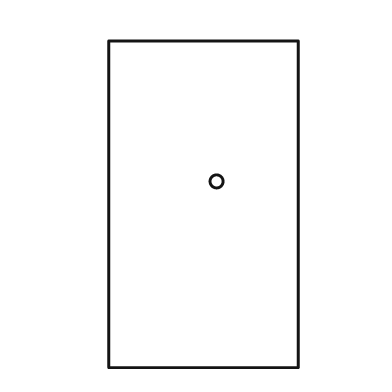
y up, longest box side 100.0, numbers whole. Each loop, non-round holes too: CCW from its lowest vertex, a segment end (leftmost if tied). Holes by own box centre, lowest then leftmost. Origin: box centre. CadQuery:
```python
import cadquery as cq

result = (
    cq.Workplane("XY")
    .moveTo(-29.0, -50.0)
    .lineTo(29.0, -50.0)
    .lineTo(29.0, 50.0)
    .lineTo(-29.0, 50.0)
    .close()
    .moveTo(4.0, 7.0)
    .circle(2.0)
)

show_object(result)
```